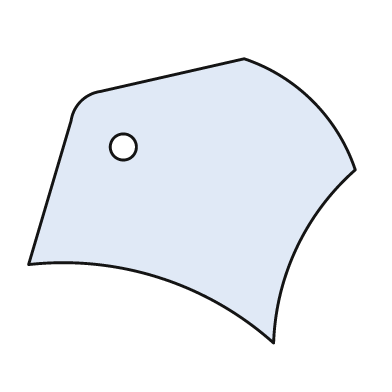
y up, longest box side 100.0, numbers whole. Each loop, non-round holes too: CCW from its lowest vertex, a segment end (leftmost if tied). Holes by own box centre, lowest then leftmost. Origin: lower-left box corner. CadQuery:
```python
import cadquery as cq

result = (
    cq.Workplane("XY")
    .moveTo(75.0, 0.0)
    .threePointArc((82.0, 29.0), (100.0, 53.0))
    .threePointArc((87.0, 74.0), (66.0, 87.0))
    .lineTo(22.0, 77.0)
    .threePointArc((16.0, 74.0), (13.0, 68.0))
    .lineTo(0.0, 24.0)
    .threePointArc((40.0, 20.0), (75.0, 0.0))
    .close()
    .moveTo(29.0, 60.0)
    .circle(4.0)
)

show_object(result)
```